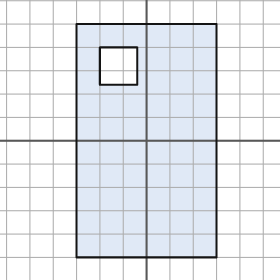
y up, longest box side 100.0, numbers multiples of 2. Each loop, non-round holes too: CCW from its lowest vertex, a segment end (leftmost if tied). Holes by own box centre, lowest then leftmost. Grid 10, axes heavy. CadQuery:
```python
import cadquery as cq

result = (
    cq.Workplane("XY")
    .moveTo(-30.0, -50.0)
    .lineTo(30.0, -50.0)
    .lineTo(30.0, 50.0)
    .lineTo(-30.0, 50.0)
    .close()
    .moveTo(-20.0, 24.0)
    .lineTo(-4.0, 24.0)
    .lineTo(-4.0, 40.0)
    .lineTo(-20.0, 40.0)
    .close()
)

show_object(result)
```